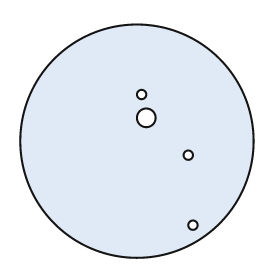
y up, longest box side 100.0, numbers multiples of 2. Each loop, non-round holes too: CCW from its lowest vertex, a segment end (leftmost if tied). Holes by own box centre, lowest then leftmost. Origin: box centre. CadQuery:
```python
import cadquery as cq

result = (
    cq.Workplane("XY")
    .moveTo(0.0, 0.0)
    .circle(50.0)
    .moveTo(24.0, -36.0)
    .circle(2.0)
    .moveTo(22.0, -6.0)
    .circle(2.0)
    .moveTo(4.0, 10.0)
    .circle(4.0)
    .moveTo(2.0, 20.0)
    .circle(2.0)
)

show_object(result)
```